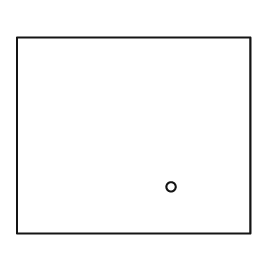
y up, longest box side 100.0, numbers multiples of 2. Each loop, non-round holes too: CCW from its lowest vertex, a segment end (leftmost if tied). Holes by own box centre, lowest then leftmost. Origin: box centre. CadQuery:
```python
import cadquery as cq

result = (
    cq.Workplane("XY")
    .moveTo(-50.0, -42.0)
    .lineTo(50.0, -42.0)
    .lineTo(50.0, 42.0)
    .lineTo(-50.0, 42.0)
    .close()
    .moveTo(16.0, -22.0)
    .circle(2.0)
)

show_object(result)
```